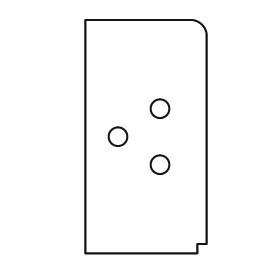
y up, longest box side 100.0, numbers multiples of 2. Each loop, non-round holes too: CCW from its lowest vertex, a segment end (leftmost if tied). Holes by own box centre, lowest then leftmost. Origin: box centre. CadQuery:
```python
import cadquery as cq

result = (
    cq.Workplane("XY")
    .moveTo(-26.0, -50.0)
    .lineTo(22.0, -50.0)
    .lineTo(22.0, -46.0)
    .lineTo(26.0, -46.0)
    .lineTo(26.0, 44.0)
    .threePointArc((24.0, 48.0), (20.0, 50.0))
    .lineTo(-26.0, 50.0)
    .close()
    .moveTo(6.0, -12.0)
    .circle(4.0)
    .moveTo(-12.0, 0.0)
    .circle(4.0)
    .moveTo(6.0, 12.0)
    .circle(4.0)
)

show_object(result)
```